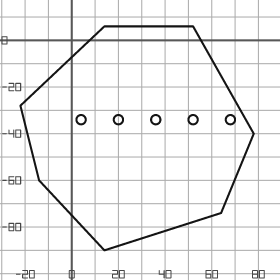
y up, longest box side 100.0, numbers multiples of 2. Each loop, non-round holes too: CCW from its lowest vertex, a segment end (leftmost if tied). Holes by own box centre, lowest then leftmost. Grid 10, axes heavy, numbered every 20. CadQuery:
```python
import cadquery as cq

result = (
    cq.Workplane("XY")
    .moveTo(14.0, -90.0)
    .lineTo(64.0, -74.0)
    .lineTo(78.0, -40.0)
    .lineTo(52.0, 6.0)
    .lineTo(14.0, 6.0)
    .lineTo(-22.0, -28.0)
    .lineTo(-14.0, -60.0)
    .close()
    .moveTo(4.0, -34.0)
    .circle(2.0)
    .moveTo(20.0, -34.0)
    .circle(2.0)
    .moveTo(36.0, -34.0)
    .circle(2.0)
    .moveTo(52.0, -34.0)
    .circle(2.0)
    .moveTo(68.0, -34.0)
    .circle(2.0)
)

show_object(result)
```